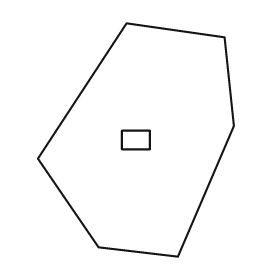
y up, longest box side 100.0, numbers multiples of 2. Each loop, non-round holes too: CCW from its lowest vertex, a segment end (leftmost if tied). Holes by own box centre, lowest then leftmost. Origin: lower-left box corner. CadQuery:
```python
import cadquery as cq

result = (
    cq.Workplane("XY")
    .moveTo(60.0, 0.0)
    .lineTo(84.0, 56.0)
    .lineTo(80.0, 94.0)
    .lineTo(38.0, 100.0)
    .lineTo(0.0, 42.0)
    .lineTo(26.0, 4.0)
    .close()
    .moveTo(36.0, 46.0)
    .lineTo(48.0, 46.0)
    .lineTo(48.0, 54.0)
    .lineTo(36.0, 54.0)
    .close()
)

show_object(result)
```